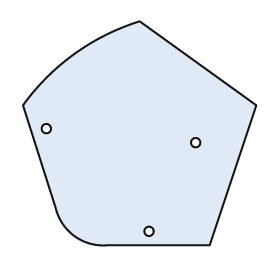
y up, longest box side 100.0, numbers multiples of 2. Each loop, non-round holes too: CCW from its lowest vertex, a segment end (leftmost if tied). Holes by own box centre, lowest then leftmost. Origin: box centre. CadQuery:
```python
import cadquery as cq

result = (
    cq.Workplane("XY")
    .moveTo(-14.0, -48.0)
    .lineTo(30.0, -48.0)
    .lineTo(50.0, 12.0)
    .lineTo(0.0, 48.0)
    .threePointArc((-28.0, 34.0), (-50.0, 12.0))
    .lineTo(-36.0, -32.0)
    .threePointArc((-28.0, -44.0), (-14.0, -48.0))
    .close()
    .moveTo(4.0, -42.0)
    .circle(2.0)
    .moveTo(24.0, -4.0)
    .circle(2.0)
    .moveTo(-40.0, 2.0)
    .circle(2.0)
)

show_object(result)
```